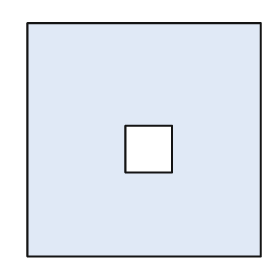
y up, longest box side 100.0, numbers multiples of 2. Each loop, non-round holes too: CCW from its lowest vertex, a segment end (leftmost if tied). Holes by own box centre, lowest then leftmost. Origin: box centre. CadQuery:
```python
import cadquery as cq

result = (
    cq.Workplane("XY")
    .moveTo(-50.0, -50.0)
    .lineTo(50.0, -50.0)
    .lineTo(50.0, 50.0)
    .lineTo(-50.0, 50.0)
    .close()
    .moveTo(-8.0, -14.0)
    .lineTo(12.0, -14.0)
    .lineTo(12.0, 6.0)
    .lineTo(-8.0, 6.0)
    .close()
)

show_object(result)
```